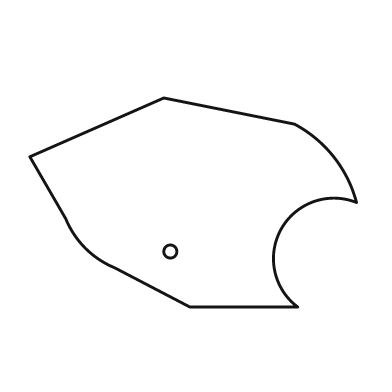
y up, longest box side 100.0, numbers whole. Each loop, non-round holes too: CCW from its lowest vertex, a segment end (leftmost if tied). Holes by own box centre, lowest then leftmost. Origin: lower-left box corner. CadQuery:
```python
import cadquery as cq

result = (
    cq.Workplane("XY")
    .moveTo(49.0, 0.0)
    .lineTo(82.0, 0.0)
    .threePointArc((77.0, 24.0), (100.0, 32.0))
    .threePointArc((93.0, 46.0), (81.0, 56.0))
    .lineTo(41.0, 64.0)
    .lineTo(0.0, 46.0)
    .lineTo(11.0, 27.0)
    .threePointArc((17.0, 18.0), (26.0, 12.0))
    .close()
    .moveTo(43.0, 17.0)
    .circle(2.0)
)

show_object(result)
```